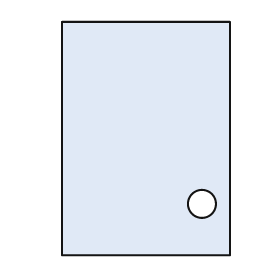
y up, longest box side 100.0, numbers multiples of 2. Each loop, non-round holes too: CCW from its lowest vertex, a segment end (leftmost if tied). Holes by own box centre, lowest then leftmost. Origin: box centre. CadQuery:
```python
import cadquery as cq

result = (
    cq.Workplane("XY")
    .moveTo(-36.0, -50.0)
    .lineTo(36.0, -50.0)
    .lineTo(36.0, 50.0)
    .lineTo(-36.0, 50.0)
    .close()
    .moveTo(24.0, -28.0)
    .circle(6.0)
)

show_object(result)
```